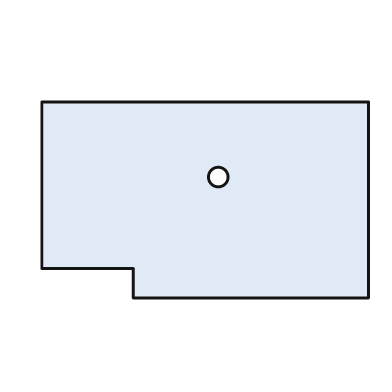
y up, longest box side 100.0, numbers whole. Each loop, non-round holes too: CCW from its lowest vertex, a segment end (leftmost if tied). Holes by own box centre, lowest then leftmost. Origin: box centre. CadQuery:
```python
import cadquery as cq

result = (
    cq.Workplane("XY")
    .moveTo(-22.0, -30.0)
    .lineTo(50.0, -30.0)
    .lineTo(50.0, 30.0)
    .lineTo(-50.0, 30.0)
    .lineTo(-50.0, -21.0)
    .lineTo(-22.0, -21.0)
    .close()
    .moveTo(4.0, 7.0)
    .circle(3.0)
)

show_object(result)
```